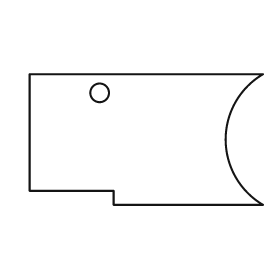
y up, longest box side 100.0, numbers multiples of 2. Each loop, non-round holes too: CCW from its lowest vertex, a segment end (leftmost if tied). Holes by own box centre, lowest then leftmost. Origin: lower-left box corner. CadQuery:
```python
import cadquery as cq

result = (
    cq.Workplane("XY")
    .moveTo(36.0, 0.0)
    .lineTo(100.0, 0.0)
    .threePointArc((84.0, 28.0), (100.0, 56.0))
    .lineTo(0.0, 56.0)
    .lineTo(0.0, 6.0)
    .lineTo(36.0, 6.0)
    .close()
    .moveTo(30.0, 48.0)
    .circle(4.0)
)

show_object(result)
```